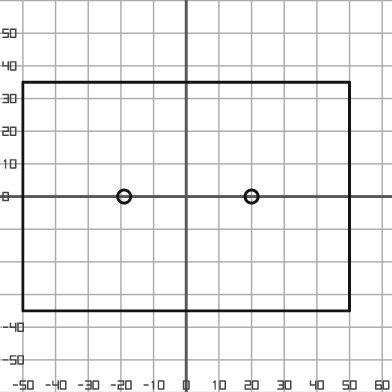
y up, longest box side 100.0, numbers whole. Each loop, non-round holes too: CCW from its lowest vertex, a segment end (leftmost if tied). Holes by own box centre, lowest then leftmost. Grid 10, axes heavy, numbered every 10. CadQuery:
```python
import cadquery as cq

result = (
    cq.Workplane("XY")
    .moveTo(-50.0, -35.0)
    .lineTo(50.0, -35.0)
    .lineTo(50.0, 35.0)
    .lineTo(-50.0, 35.0)
    .close()
    .moveTo(-19.0, 0.0)
    .circle(2.0)
    .moveTo(20.0, 0.0)
    .circle(2.0)
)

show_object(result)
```